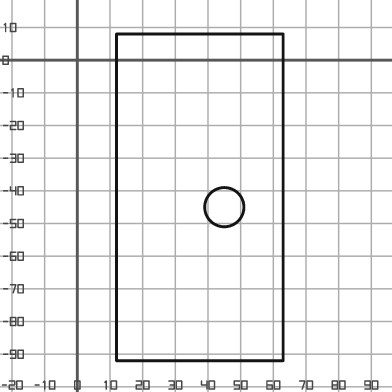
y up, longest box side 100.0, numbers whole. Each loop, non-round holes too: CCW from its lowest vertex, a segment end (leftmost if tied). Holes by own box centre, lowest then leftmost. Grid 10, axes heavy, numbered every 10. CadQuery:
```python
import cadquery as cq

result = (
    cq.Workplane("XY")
    .moveTo(12.0, -92.0)
    .lineTo(63.0, -92.0)
    .lineTo(63.0, 8.0)
    .lineTo(12.0, 8.0)
    .close()
    .moveTo(45.0, -45.0)
    .circle(6.0)
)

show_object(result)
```